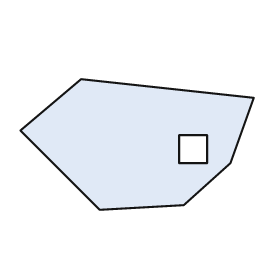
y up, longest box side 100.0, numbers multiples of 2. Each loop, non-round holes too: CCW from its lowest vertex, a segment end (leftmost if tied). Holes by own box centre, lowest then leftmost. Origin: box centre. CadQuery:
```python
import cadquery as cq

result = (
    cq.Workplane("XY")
    .moveTo(-16.0, -28.0)
    .lineTo(20.0, -26.0)
    .lineTo(40.0, -8.0)
    .lineTo(50.0, 20.0)
    .lineTo(-24.0, 28.0)
    .lineTo(-50.0, 6.0)
    .close()
    .moveTo(18.0, -8.0)
    .lineTo(30.0, -8.0)
    .lineTo(30.0, 4.0)
    .lineTo(18.0, 4.0)
    .close()
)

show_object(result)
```